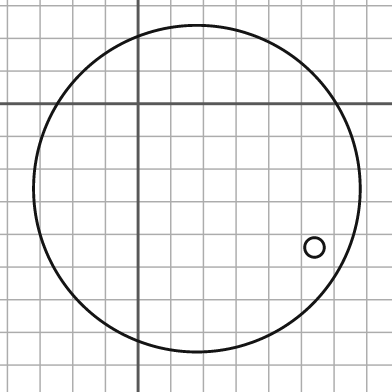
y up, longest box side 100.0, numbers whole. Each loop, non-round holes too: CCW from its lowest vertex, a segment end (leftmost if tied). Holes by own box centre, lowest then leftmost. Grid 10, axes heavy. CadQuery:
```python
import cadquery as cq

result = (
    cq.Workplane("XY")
    .moveTo(18.0, -26.0)
    .circle(50.0)
    .moveTo(54.0, -44.0)
    .circle(3.0)
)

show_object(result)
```